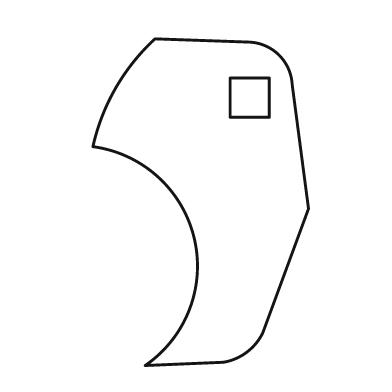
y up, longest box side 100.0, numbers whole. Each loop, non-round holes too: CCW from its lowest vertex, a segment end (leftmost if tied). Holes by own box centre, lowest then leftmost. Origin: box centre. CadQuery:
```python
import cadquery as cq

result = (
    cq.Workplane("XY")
    .moveTo(-17.0, -50.0)
    .lineTo(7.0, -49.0)
    .threePointArc((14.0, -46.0), (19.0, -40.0))
    .lineTo(33.0, -2.0)
    .lineTo(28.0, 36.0)
    .threePointArc((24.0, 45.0), (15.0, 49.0))
    .lineTo(-14.0, 50.0)
    .threePointArc((-26.0, 35.0), (-33.0, 17.0))
    .threePointArc((-2.0, -11.0), (-17.0, -50.0))
    .close()
    .moveTo(9.0, 26.0)
    .lineTo(21.0, 26.0)
    .lineTo(21.0, 38.0)
    .lineTo(9.0, 38.0)
    .close()
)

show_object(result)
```